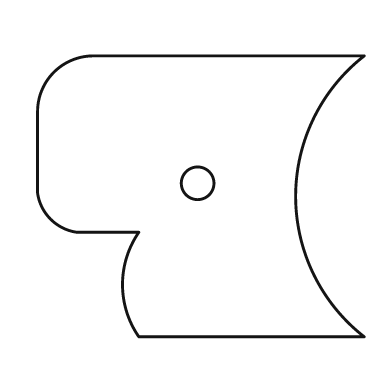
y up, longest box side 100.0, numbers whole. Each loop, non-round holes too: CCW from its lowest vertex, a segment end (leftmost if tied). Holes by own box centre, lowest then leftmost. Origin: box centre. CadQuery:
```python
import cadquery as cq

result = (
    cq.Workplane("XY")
    .moveTo(-19.0, -43.0)
    .lineTo(50.0, -43.0)
    .threePointArc((29.0, 0.0), (50.0, 43.0))
    .lineTo(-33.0, 43.0)
    .threePointArc((-45.0, 38.0), (-50.0, 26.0))
    .lineTo(-50.0, 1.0)
    .threePointArc((-46.0, -7.0), (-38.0, -11.0))
    .lineTo(-19.0, -11.0)
    .threePointArc((-24.0, -27.0), (-19.0, -43.0))
    .close()
    .moveTo(-1.0, 4.0)
    .circle(5.0)
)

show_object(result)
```